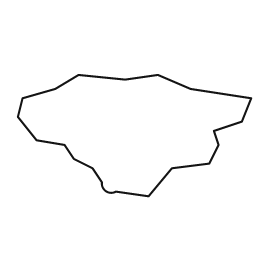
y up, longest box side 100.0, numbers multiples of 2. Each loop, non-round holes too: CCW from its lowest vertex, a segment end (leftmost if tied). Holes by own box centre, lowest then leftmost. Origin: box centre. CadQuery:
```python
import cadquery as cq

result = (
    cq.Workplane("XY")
    .moveTo(6.0, -26.0)
    .lineTo(16.0, -14.0)
    .lineTo(32.0, -12.0)
    .lineTo(36.0, -4.0)
    .lineTo(34.0, 2.0)
    .lineTo(46.0, 6.0)
    .lineTo(50.0, 16.0)
    .lineTo(24.0, 20.0)
    .lineTo(10.0, 26.0)
    .lineTo(-4.0, 24.0)
    .lineTo(-24.0, 26.0)
    .lineTo(-34.0, 20.0)
    .lineTo(-48.0, 16.0)
    .lineTo(-50.0, 8.0)
    .lineTo(-42.0, -2.0)
    .lineTo(-30.0, -4.0)
    .lineTo(-26.0, -10.0)
    .lineTo(-18.0, -14.0)
    .lineTo(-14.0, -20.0)
    .threePointArc((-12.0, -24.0), (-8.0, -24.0))
    .close()
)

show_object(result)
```